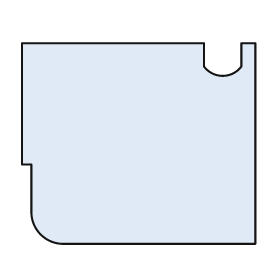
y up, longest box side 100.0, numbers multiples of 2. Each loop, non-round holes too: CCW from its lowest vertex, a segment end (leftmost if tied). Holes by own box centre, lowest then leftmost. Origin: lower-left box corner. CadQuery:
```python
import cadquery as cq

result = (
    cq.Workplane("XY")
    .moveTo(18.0, 0.0)
    .lineTo(100.0, 0.0)
    .lineTo(100.0, 86.0)
    .lineTo(94.0, 86.0)
    .lineTo(94.0, 76.0)
    .threePointArc((86.0, 72.0), (78.0, 76.0))
    .lineTo(78.0, 86.0)
    .lineTo(0.0, 86.0)
    .lineTo(0.0, 34.0)
    .lineTo(4.0, 34.0)
    .lineTo(4.0, 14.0)
    .threePointArc((8.0, 4.0), (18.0, 0.0))
    .close()
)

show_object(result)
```